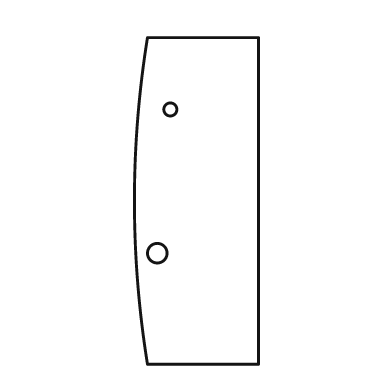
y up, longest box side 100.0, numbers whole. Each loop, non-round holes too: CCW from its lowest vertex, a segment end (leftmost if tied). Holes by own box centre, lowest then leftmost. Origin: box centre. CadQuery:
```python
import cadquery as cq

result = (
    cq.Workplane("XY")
    .moveTo(-15.0, -50.0)
    .lineTo(19.0, -50.0)
    .lineTo(19.0, 50.0)
    .lineTo(-15.0, 50.0)
    .threePointArc((-19.0, 0.0), (-15.0, -50.0))
    .close()
    .moveTo(-12.0, -16.0)
    .circle(3.0)
    .moveTo(-8.0, 28.0)
    .circle(2.0)
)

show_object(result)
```